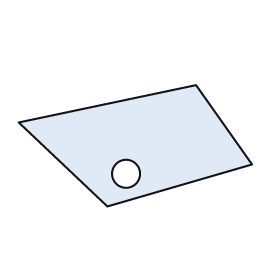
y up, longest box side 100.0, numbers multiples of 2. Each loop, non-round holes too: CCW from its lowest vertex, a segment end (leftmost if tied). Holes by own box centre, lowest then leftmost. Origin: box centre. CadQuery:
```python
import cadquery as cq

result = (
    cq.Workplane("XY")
    .moveTo(-12.0, -26.0)
    .lineTo(50.0, -8.0)
    .lineTo(26.0, 26.0)
    .lineTo(-50.0, 10.0)
    .close()
    .moveTo(-4.0, -12.0)
    .circle(6.0)
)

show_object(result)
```